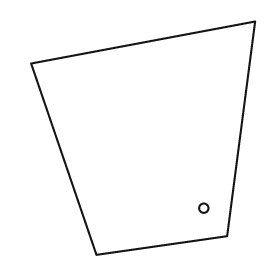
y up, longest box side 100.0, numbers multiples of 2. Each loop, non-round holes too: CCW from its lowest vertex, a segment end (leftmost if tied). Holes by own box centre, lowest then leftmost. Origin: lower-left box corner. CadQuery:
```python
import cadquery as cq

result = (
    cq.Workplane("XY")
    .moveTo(28.0, 0.0)
    .lineTo(84.0, 8.0)
    .lineTo(96.0, 100.0)
    .lineTo(0.0, 82.0)
    .close()
    .moveTo(74.0, 20.0)
    .circle(2.0)
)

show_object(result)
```